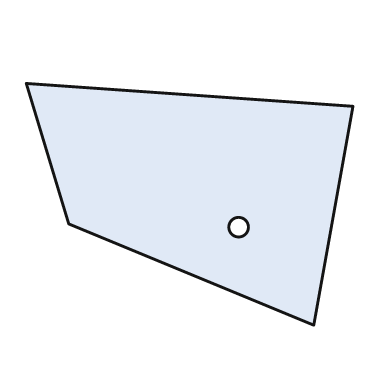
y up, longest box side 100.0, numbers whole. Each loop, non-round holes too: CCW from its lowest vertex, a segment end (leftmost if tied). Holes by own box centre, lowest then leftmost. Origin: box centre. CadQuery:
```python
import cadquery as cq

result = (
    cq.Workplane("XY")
    .moveTo(38.0, -37.0)
    .lineTo(50.0, 30.0)
    .lineTo(-50.0, 37.0)
    .lineTo(-37.0, -6.0)
    .close()
    .moveTo(15.0, -7.0)
    .circle(3.0)
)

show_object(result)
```